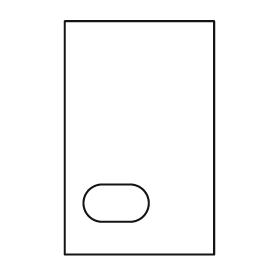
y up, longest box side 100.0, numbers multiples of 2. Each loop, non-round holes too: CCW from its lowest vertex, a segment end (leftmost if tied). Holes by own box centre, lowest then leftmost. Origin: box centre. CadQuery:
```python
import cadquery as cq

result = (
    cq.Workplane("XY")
    .moveTo(-32.0, -50.0)
    .lineTo(32.0, -50.0)
    .lineTo(32.0, 50.0)
    .lineTo(-32.0, 50.0)
    .close()
    .moveTo(-16.0, -36.0)
    .lineTo(-4.0, -36.0)
    .threePointArc((4.0, -28.0), (-4.0, -20.0))
    .lineTo(-16.0, -20.0)
    .threePointArc((-24.0, -28.0), (-16.0, -36.0))
    .close()
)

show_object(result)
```